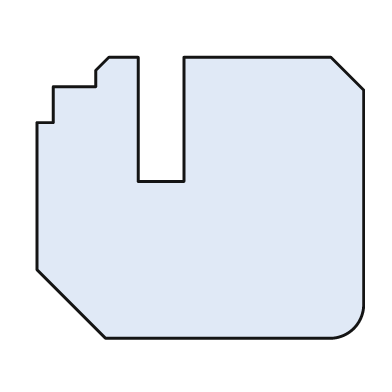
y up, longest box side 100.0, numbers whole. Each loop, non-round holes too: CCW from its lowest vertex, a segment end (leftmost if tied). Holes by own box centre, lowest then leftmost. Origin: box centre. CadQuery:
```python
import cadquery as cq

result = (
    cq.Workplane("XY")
    .moveTo(-29.0, -43.0)
    .lineTo(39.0, -43.0)
    .threePointArc((47.0, -40.0), (50.0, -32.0))
    .lineTo(50.0, 33.0)
    .lineTo(40.0, 43.0)
    .lineTo(-5.0, 43.0)
    .lineTo(-5.0, 5.0)
    .lineTo(-19.0, 5.0)
    .lineTo(-19.0, 43.0)
    .lineTo(-28.0, 43.0)
    .lineTo(-32.0, 39.0)
    .lineTo(-32.0, 34.0)
    .lineTo(-45.0, 34.0)
    .lineTo(-45.0, 23.0)
    .lineTo(-50.0, 23.0)
    .lineTo(-50.0, -22.0)
    .close()
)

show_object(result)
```